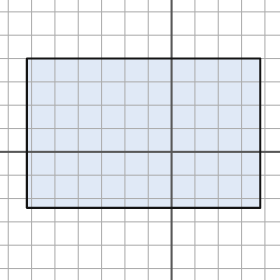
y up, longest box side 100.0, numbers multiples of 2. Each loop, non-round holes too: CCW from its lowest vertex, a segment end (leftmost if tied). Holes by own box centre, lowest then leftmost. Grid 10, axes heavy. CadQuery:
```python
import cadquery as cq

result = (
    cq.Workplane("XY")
    .moveTo(-62.0, -24.0)
    .lineTo(38.0, -24.0)
    .lineTo(38.0, 40.0)
    .lineTo(-62.0, 40.0)
    .close()
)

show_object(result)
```